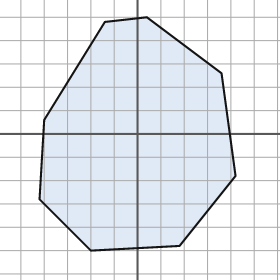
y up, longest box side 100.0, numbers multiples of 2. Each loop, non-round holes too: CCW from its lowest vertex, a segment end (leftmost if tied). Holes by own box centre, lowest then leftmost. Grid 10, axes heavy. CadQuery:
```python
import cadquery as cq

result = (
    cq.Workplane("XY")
    .moveTo(-20.0, -50.0)
    .lineTo(18.0, -48.0)
    .lineTo(42.0, -18.0)
    .lineTo(36.0, 26.0)
    .lineTo(4.0, 50.0)
    .lineTo(-14.0, 48.0)
    .lineTo(-40.0, 6.0)
    .lineTo(-42.0, -28.0)
    .close()
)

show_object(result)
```